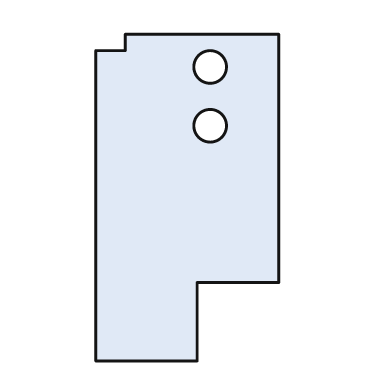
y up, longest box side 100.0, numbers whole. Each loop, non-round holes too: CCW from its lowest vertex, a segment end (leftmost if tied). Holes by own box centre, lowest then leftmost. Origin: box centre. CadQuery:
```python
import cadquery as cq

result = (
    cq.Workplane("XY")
    .moveTo(-28.0, -50.0)
    .lineTo(3.0, -50.0)
    .lineTo(3.0, -26.0)
    .lineTo(28.0, -26.0)
    .lineTo(28.0, 50.0)
    .lineTo(-19.0, 50.0)
    .lineTo(-19.0, 45.0)
    .lineTo(-28.0, 45.0)
    .close()
    .moveTo(7.0, 22.0)
    .circle(5.0)
    .moveTo(7.0, 40.0)
    .circle(5.0)
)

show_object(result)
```